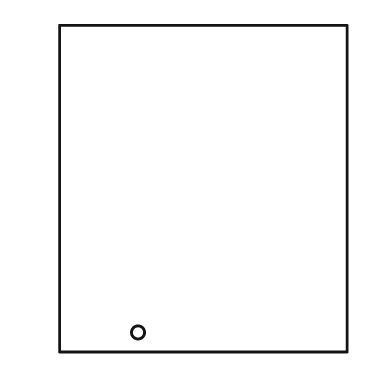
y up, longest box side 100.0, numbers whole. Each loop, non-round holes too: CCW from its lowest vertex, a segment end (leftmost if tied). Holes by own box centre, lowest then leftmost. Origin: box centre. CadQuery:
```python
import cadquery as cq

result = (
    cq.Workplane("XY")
    .moveTo(-44.0, -50.0)
    .lineTo(44.0, -50.0)
    .lineTo(44.0, 50.0)
    .lineTo(-44.0, 50.0)
    .close()
    .moveTo(-20.0, -44.0)
    .circle(2.0)
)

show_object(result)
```